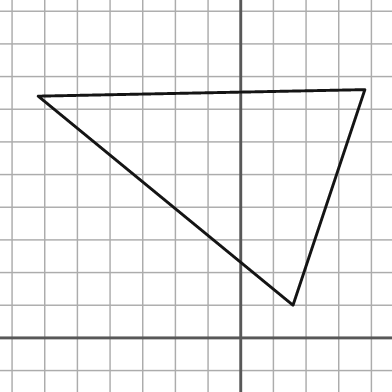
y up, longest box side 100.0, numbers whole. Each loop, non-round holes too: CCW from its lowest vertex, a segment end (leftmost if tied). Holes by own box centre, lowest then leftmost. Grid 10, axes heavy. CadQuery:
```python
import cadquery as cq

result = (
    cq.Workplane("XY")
    .moveTo(16.0, 10.0)
    .lineTo(38.0, 76.0)
    .lineTo(-62.0, 74.0)
    .close()
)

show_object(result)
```